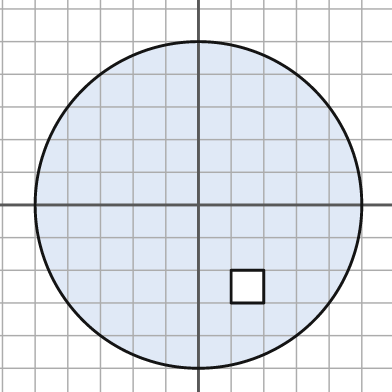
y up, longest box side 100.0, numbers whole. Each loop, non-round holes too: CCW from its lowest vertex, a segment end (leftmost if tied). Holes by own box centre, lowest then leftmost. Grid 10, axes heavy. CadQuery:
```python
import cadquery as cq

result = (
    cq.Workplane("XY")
    .moveTo(0.0, 0.0)
    .circle(50.0)
    .moveTo(10.0, -30.0)
    .lineTo(20.0, -30.0)
    .lineTo(20.0, -20.0)
    .lineTo(10.0, -20.0)
    .close()
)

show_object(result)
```